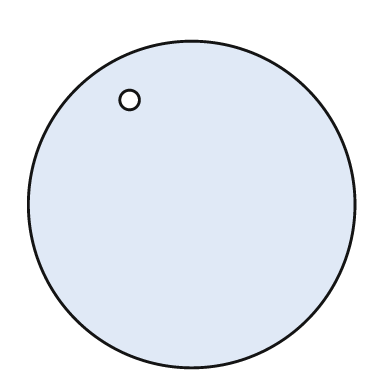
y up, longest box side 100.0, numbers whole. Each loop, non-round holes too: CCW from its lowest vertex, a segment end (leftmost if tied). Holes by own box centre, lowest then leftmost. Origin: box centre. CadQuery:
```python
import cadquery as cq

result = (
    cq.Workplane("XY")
    .moveTo(0.0, 0.0)
    .circle(50.0)
    .moveTo(-19.0, 32.0)
    .circle(3.0)
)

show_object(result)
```